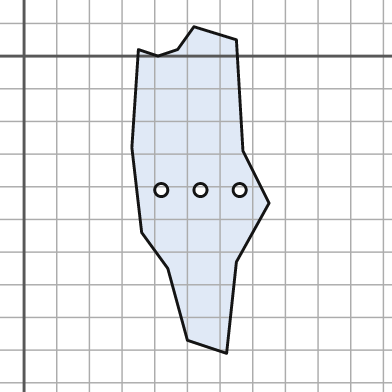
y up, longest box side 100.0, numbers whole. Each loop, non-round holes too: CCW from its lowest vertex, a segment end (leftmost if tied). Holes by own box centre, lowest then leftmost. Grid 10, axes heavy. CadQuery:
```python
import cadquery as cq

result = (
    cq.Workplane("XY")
    .moveTo(62.0, -91.0)
    .lineTo(65.0, -63.0)
    .lineTo(75.0, -45.0)
    .lineTo(67.0, -29.0)
    .lineTo(65.0, 5.0)
    .lineTo(52.0, 9.0)
    .lineTo(47.0, 2.0)
    .lineTo(41.0, 0.0)
    .lineTo(35.0, 2.0)
    .lineTo(33.0, -28.0)
    .lineTo(36.0, -54.0)
    .lineTo(44.0, -65.0)
    .lineTo(50.0, -87.0)
    .close()
    .moveTo(42.0, -41.0)
    .circle(2.0)
    .moveTo(54.0, -41.0)
    .circle(2.0)
    .moveTo(66.0, -41.0)
    .circle(2.0)
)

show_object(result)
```